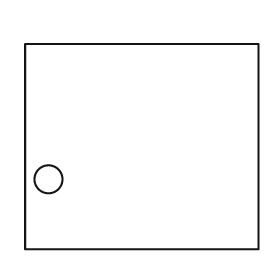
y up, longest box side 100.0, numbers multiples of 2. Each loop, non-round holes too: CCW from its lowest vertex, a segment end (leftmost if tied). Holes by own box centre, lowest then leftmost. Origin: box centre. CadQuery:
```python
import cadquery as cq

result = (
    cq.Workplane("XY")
    .moveTo(-50.0, -44.0)
    .lineTo(50.0, -44.0)
    .lineTo(50.0, 44.0)
    .lineTo(-50.0, 44.0)
    .close()
    .moveTo(-40.0, -14.0)
    .circle(6.0)
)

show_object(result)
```